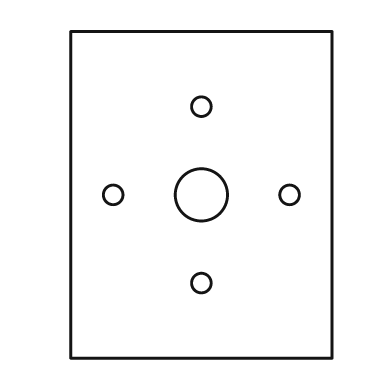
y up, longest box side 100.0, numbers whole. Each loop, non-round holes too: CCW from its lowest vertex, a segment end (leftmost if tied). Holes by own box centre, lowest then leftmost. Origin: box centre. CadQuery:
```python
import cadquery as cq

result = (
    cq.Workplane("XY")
    .moveTo(-40.0, -50.0)
    .lineTo(40.0, -50.0)
    .lineTo(40.0, 50.0)
    .lineTo(-40.0, 50.0)
    .close()
    .moveTo(0.0, -27.0)
    .circle(3.0)
    .moveTo(-27.0, 0.0)
    .circle(3.0)
    .moveTo(0.0, 0.0)
    .circle(8.0)
    .moveTo(27.0, 0.0)
    .circle(3.0)
    .moveTo(0.0, 27.0)
    .circle(3.0)
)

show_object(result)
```